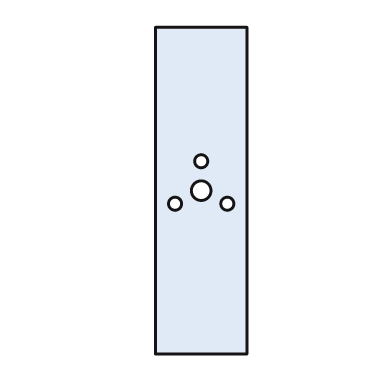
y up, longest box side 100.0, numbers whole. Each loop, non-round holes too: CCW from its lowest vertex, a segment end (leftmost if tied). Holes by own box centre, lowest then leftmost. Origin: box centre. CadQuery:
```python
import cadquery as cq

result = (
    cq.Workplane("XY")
    .moveTo(-14.0, -50.0)
    .lineTo(14.0, -50.0)
    .lineTo(14.0, 50.0)
    .lineTo(-14.0, 50.0)
    .close()
    .moveTo(-8.0, -4.0)
    .circle(2.0)
    .moveTo(8.0, -4.0)
    .circle(2.0)
    .moveTo(0.0, 0.0)
    .circle(3.0)
    .moveTo(0.0, 9.0)
    .circle(2.0)
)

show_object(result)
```